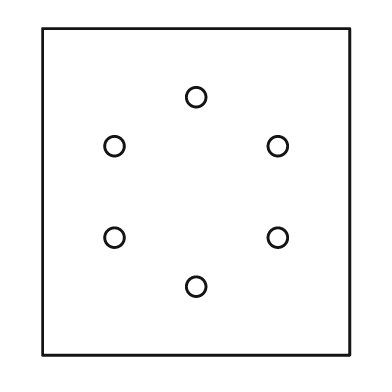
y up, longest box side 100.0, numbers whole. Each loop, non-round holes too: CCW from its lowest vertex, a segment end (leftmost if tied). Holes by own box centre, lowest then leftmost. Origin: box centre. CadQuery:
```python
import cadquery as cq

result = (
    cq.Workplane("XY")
    .moveTo(-47.0, -50.0)
    .lineTo(47.0, -50.0)
    .lineTo(47.0, 50.0)
    .lineTo(-47.0, 50.0)
    .close()
    .moveTo(0.0, -29.0)
    .circle(3.0)
    .moveTo(-25.0, -14.0)
    .circle(3.0)
    .moveTo(25.0, -14.0)
    .circle(3.0)
    .moveTo(-25.0, 14.0)
    .circle(3.0)
    .moveTo(25.0, 14.0)
    .circle(3.0)
    .moveTo(0.0, 29.0)
    .circle(3.0)
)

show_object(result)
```